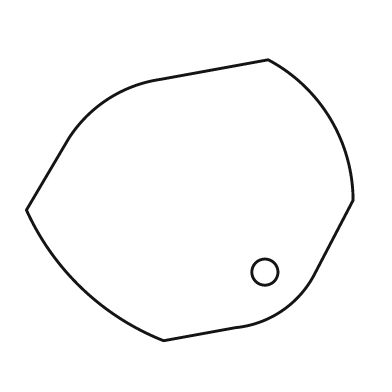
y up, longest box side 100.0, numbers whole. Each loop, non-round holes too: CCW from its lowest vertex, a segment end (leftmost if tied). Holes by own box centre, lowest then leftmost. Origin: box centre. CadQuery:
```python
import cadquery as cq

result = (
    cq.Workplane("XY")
    .moveTo(-8.0, -43.0)
    .lineTo(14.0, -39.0)
    .threePointArc((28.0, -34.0), (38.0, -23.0))
    .lineTo(50.0, 0.0)
    .threePointArc((43.0, 25.0), (24.0, 43.0))
    .lineTo(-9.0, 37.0)
    .threePointArc((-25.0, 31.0), (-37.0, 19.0))
    .lineTo(-50.0, -3.0)
    .threePointArc((-33.0, -27.0), (-8.0, -43.0))
    .close()
    .moveTo(23.0, -22.0)
    .circle(4.0)
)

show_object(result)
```